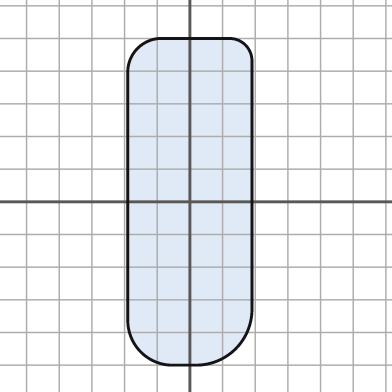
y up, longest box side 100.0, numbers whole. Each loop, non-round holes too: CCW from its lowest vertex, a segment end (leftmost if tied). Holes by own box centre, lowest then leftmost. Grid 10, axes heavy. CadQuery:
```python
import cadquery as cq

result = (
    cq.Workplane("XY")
    .moveTo(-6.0, -50.0)
    .lineTo(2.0, -50.0)
    .threePointArc((14.0, -45.0), (19.0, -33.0))
    .lineTo(19.0, 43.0)
    .threePointArc((17.0, 48.0), (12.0, 50.0))
    .lineTo(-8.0, 50.0)
    .threePointArc((-16.0, 47.0), (-19.0, 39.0))
    .lineTo(-19.0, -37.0)
    .threePointArc((-15.0, -46.0), (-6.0, -50.0))
    .close()
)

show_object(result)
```